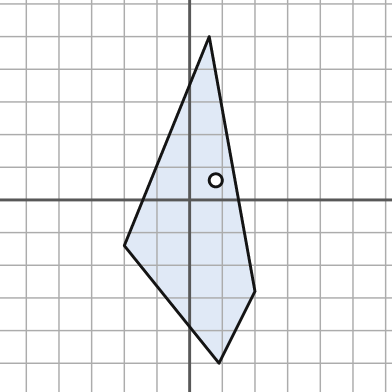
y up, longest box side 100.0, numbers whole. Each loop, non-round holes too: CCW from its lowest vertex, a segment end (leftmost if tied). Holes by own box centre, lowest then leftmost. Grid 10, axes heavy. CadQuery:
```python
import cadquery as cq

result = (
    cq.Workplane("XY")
    .moveTo(9.0, -50.0)
    .lineTo(20.0, -28.0)
    .lineTo(6.0, 50.0)
    .lineTo(-20.0, -14.0)
    .close()
    .moveTo(8.0, 6.0)
    .circle(2.0)
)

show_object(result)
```